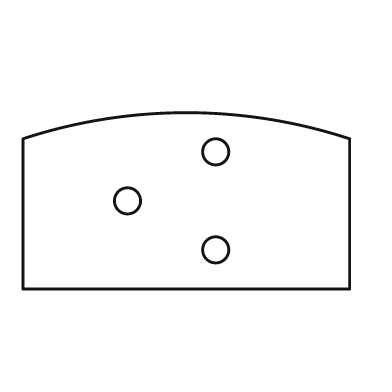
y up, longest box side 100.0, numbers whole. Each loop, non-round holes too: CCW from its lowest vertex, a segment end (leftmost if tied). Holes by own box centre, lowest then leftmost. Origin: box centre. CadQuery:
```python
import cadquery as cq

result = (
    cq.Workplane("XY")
    .moveTo(-50.0, -27.0)
    .lineTo(50.0, -27.0)
    .lineTo(50.0, 19.0)
    .threePointArc((0.0, 27.0), (-50.0, 19.0))
    .close()
    .moveTo(9.0, -15.0)
    .circle(4.0)
    .moveTo(-18.0, 0.0)
    .circle(4.0)
    .moveTo(9.0, 15.0)
    .circle(4.0)
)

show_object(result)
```